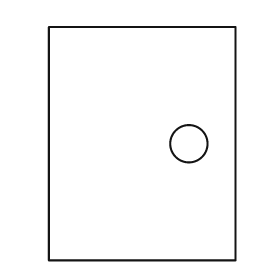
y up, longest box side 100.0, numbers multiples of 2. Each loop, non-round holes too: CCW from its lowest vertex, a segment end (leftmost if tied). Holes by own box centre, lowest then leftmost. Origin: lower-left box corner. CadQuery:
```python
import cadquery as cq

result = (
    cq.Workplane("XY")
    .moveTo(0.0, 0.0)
    .lineTo(80.0, 0.0)
    .lineTo(80.0, 100.0)
    .lineTo(0.0, 100.0)
    .close()
    .moveTo(60.0, 50.0)
    .circle(8.0)
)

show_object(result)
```